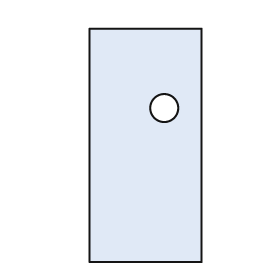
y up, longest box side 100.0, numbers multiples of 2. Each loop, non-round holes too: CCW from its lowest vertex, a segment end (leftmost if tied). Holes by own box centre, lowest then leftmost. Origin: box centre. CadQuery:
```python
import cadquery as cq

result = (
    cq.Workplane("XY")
    .moveTo(-24.0, -50.0)
    .lineTo(24.0, -50.0)
    .lineTo(24.0, 50.0)
    .lineTo(-24.0, 50.0)
    .close()
    .moveTo(8.0, 16.0)
    .circle(6.0)
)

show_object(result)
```